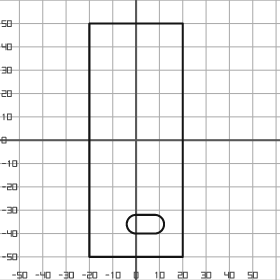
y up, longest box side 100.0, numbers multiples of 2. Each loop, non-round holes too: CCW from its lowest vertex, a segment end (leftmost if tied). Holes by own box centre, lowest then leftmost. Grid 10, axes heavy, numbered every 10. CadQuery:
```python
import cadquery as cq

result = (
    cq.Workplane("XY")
    .moveTo(-20.0, -50.0)
    .lineTo(20.0, -50.0)
    .lineTo(20.0, 50.0)
    .lineTo(-20.0, 50.0)
    .close()
    .moveTo(0.0, -40.0)
    .lineTo(8.0, -40.0)
    .threePointArc((12.0, -36.0), (8.0, -32.0))
    .lineTo(0.0, -32.0)
    .threePointArc((-4.0, -36.0), (0.0, -40.0))
    .close()
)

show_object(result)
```